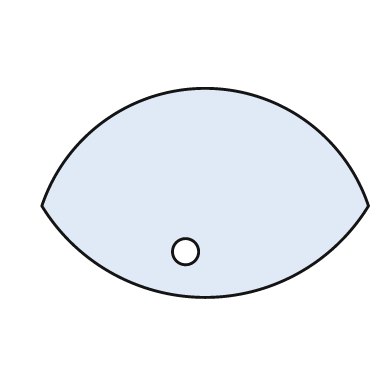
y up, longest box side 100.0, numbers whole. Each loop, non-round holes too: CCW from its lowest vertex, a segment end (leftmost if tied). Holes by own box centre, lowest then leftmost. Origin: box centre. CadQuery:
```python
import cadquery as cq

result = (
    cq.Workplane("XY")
    .moveTo(-50.0, -4.0)
    .threePointArc((0.0, -32.0), (50.0, -4.0))
    .threePointArc((0.0, 32.0), (-50.0, -4.0))
    .close()
    .moveTo(-6.0, -18.0)
    .circle(4.0)
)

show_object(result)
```